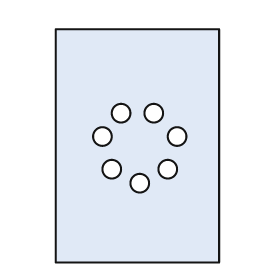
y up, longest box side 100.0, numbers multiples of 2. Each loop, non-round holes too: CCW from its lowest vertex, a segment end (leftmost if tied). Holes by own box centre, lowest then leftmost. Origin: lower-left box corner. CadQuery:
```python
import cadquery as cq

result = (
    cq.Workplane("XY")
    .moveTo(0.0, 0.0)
    .lineTo(70.0, 0.0)
    .lineTo(70.0, 100.0)
    .lineTo(0.0, 100.0)
    .close()
    .moveTo(36.0, 34.0)
    .circle(4.0)
    .moveTo(24.0, 40.0)
    .circle(4.0)
    .moveTo(48.0, 40.0)
    .circle(4.0)
    .moveTo(20.0, 54.0)
    .circle(4.0)
    .moveTo(52.0, 54.0)
    .circle(4.0)
    .moveTo(28.0, 64.0)
    .circle(4.0)
    .moveTo(42.0, 64.0)
    .circle(4.0)
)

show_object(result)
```